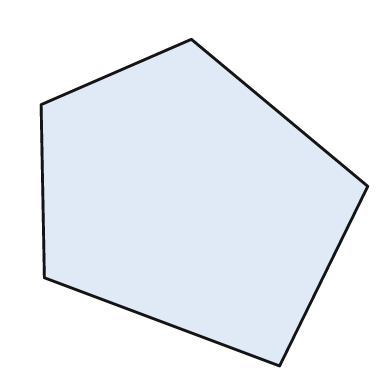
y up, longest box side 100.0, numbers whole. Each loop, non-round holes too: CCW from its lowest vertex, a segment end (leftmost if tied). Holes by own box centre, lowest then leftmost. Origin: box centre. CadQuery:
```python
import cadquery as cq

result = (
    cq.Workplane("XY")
    .moveTo(23.0, -50.0)
    .lineTo(50.0, 5.0)
    .lineTo(-4.0, 50.0)
    .lineTo(-50.0, 30.0)
    .lineTo(-49.0, -23.0)
    .close()
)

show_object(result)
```